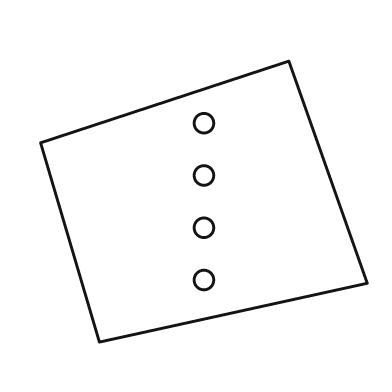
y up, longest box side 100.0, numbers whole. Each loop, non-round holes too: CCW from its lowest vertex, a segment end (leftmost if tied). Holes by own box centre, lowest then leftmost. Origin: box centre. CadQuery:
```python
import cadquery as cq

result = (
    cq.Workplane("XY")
    .moveTo(-32.0, -43.0)
    .lineTo(50.0, -25.0)
    .lineTo(26.0, 43.0)
    .lineTo(-50.0, 18.0)
    .close()
    .moveTo(0.0, -24.0)
    .circle(3.0)
    .moveTo(0.0, -8.0)
    .circle(3.0)
    .moveTo(0.0, 8.0)
    .circle(3.0)
    .moveTo(0.0, 24.0)
    .circle(3.0)
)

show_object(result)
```